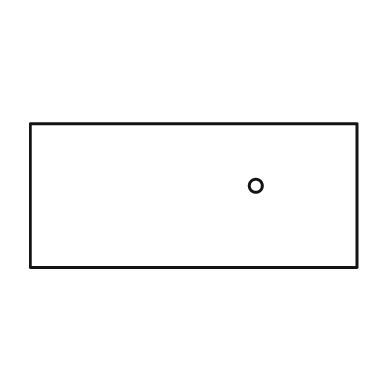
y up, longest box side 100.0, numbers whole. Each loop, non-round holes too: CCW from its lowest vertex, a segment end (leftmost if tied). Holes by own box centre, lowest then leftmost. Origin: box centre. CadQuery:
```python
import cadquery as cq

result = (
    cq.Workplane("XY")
    .moveTo(-50.0, -22.0)
    .lineTo(50.0, -22.0)
    .lineTo(50.0, 22.0)
    .lineTo(-50.0, 22.0)
    .close()
    .moveTo(19.0, 3.0)
    .circle(2.0)
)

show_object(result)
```